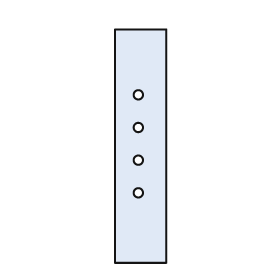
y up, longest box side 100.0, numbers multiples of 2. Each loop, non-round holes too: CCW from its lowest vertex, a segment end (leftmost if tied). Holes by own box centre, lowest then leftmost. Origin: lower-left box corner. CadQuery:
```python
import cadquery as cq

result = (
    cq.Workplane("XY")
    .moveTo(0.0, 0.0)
    .lineTo(22.0, 0.0)
    .lineTo(22.0, 100.0)
    .lineTo(0.0, 100.0)
    .close()
    .moveTo(10.0, 30.0)
    .circle(2.0)
    .moveTo(10.0, 44.0)
    .circle(2.0)
    .moveTo(10.0, 58.0)
    .circle(2.0)
    .moveTo(10.0, 72.0)
    .circle(2.0)
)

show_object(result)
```